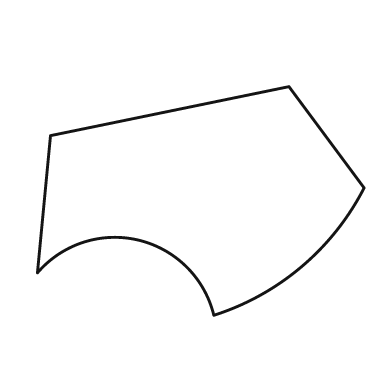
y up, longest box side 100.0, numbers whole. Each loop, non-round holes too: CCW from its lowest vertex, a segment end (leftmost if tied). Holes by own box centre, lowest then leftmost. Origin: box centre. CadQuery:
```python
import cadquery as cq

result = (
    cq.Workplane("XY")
    .moveTo(4.0, -35.0)
    .threePointArc((31.0, -20.0), (50.0, 4.0))
    .lineTo(27.0, 35.0)
    .lineTo(-46.0, 20.0)
    .lineTo(-50.0, -22.0)
    .threePointArc((-19.0, -12.0), (4.0, -35.0))
    .close()
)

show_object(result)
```